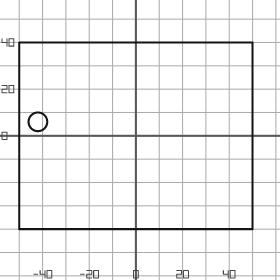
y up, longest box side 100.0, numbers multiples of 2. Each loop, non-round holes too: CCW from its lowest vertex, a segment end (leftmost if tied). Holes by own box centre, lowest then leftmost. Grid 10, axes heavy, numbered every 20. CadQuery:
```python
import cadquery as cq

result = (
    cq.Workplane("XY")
    .moveTo(-50.0, -40.0)
    .lineTo(50.0, -40.0)
    .lineTo(50.0, 40.0)
    .lineTo(-50.0, 40.0)
    .close()
    .moveTo(-42.0, 6.0)
    .circle(4.0)
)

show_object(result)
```